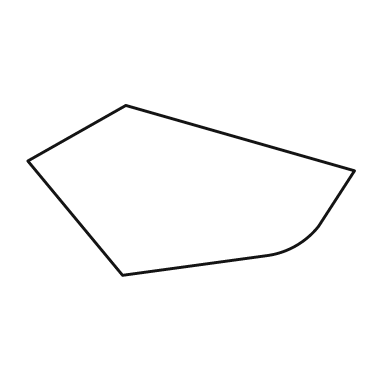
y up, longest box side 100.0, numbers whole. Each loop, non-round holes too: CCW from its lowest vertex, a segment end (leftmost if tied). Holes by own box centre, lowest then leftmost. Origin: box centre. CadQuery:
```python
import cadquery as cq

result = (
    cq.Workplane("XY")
    .moveTo(-21.0, -26.0)
    .lineTo(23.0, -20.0)
    .threePointArc((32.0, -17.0), (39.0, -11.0))
    .lineTo(50.0, 6.0)
    .lineTo(-20.0, 26.0)
    .lineTo(-50.0, 9.0)
    .close()
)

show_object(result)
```